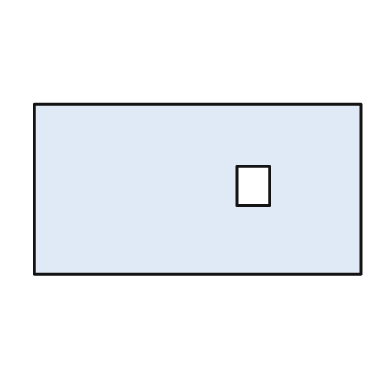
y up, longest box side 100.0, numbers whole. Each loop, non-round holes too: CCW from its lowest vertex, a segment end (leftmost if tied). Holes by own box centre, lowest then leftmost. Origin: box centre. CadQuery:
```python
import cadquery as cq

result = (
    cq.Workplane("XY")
    .moveTo(-50.0, -26.0)
    .lineTo(50.0, -26.0)
    .lineTo(50.0, 26.0)
    .lineTo(-50.0, 26.0)
    .close()
    .moveTo(12.0, -5.0)
    .lineTo(22.0, -5.0)
    .lineTo(22.0, 7.0)
    .lineTo(12.0, 7.0)
    .close()
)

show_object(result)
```